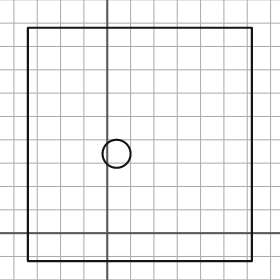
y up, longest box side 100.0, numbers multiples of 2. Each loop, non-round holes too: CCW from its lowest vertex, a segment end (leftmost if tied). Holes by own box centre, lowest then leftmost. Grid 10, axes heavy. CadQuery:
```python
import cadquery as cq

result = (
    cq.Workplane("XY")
    .moveTo(-34.0, -12.0)
    .lineTo(62.0, -12.0)
    .lineTo(62.0, 88.0)
    .lineTo(-34.0, 88.0)
    .close()
    .moveTo(4.0, 34.0)
    .circle(6.0)
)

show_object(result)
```